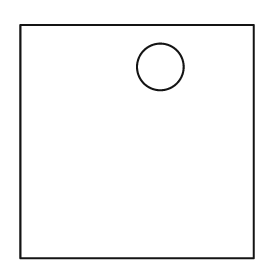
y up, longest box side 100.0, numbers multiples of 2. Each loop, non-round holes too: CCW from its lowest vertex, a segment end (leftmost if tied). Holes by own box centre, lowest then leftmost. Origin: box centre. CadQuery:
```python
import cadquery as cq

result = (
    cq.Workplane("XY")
    .moveTo(-50.0, -50.0)
    .lineTo(50.0, -50.0)
    .lineTo(50.0, 50.0)
    .lineTo(-50.0, 50.0)
    .close()
    .moveTo(10.0, 32.0)
    .circle(10.0)
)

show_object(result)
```